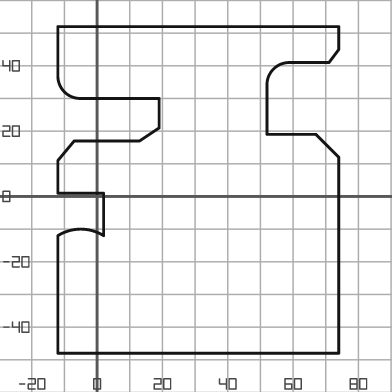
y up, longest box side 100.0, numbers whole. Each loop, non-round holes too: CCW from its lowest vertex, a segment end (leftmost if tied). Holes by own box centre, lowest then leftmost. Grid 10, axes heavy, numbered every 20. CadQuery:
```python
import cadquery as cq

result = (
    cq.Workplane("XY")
    .moveTo(-12.0, -48.0)
    .lineTo(74.0, -48.0)
    .lineTo(74.0, 12.0)
    .lineTo(67.0, 19.0)
    .lineTo(52.0, 19.0)
    .lineTo(52.0, 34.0)
    .threePointArc((54.0, 39.0), (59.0, 41.0))
    .lineTo(71.0, 41.0)
    .lineTo(74.0, 45.0)
    .lineTo(74.0, 52.0)
    .lineTo(-12.0, 52.0)
    .lineTo(-12.0, 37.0)
    .threePointArc((-10.0, 32.0), (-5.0, 30.0))
    .lineTo(19.0, 30.0)
    .lineTo(19.0, 21.0)
    .lineTo(13.0, 17.0)
    .lineTo(-7.0, 17.0)
    .lineTo(-12.0, 11.0)
    .lineTo(-12.0, 1.0)
    .lineTo(2.0, 1.0)
    .lineTo(2.0, -12.0)
    .threePointArc((-5.0, -10.0), (-12.0, -12.0))
    .close()
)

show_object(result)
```